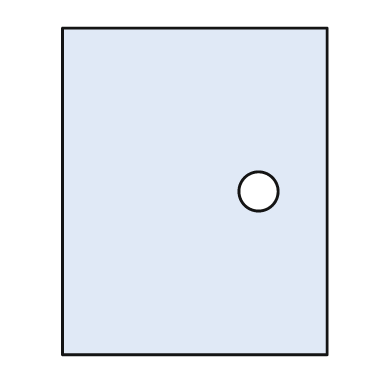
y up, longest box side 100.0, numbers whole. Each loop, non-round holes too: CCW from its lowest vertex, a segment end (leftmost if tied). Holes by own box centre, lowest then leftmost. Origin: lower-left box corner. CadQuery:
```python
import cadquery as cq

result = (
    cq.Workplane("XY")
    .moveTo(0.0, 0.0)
    .lineTo(81.0, 0.0)
    .lineTo(81.0, 100.0)
    .lineTo(0.0, 100.0)
    .close()
    .moveTo(60.0, 50.0)
    .circle(6.0)
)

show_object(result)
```